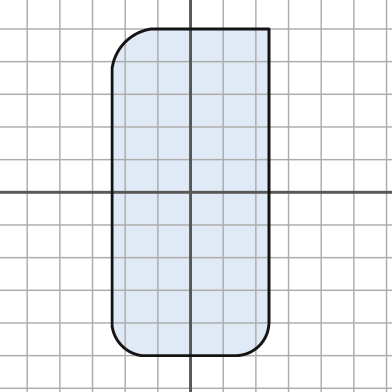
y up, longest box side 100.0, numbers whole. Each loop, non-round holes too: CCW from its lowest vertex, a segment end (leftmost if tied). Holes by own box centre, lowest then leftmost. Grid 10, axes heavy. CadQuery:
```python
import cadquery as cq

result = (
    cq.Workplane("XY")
    .moveTo(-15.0, -50.0)
    .lineTo(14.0, -50.0)
    .threePointArc((21.0, -47.0), (24.0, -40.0))
    .lineTo(24.0, 50.0)
    .lineTo(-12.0, 50.0)
    .threePointArc((-20.0, 46.0), (-24.0, 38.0))
    .lineTo(-24.0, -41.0)
    .threePointArc((-21.0, -47.0), (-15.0, -50.0))
    .close()
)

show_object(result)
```